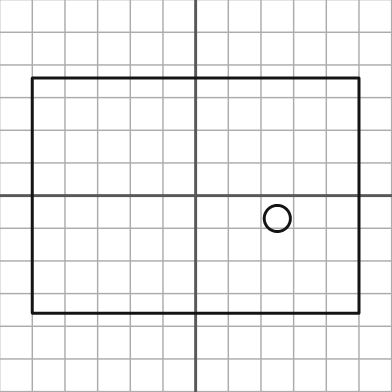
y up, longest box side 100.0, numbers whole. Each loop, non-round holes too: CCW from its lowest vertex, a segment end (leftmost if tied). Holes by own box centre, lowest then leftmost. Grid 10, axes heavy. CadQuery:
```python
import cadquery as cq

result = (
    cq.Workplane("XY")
    .moveTo(-50.0, -36.0)
    .lineTo(50.0, -36.0)
    .lineTo(50.0, 36.0)
    .lineTo(-50.0, 36.0)
    .close()
    .moveTo(25.0, -7.0)
    .circle(4.0)
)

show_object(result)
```